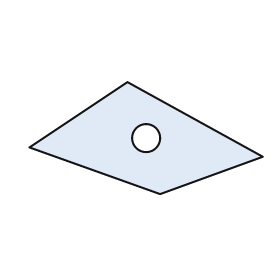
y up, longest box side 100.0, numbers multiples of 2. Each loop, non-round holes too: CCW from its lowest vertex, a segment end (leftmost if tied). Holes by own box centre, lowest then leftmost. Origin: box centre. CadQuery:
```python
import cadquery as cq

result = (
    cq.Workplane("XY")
    .moveTo(6.0, -24.0)
    .lineTo(50.0, -8.0)
    .lineTo(-8.0, 24.0)
    .lineTo(-50.0, -4.0)
    .close()
    .moveTo(0.0, 0.0)
    .circle(6.0)
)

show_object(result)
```